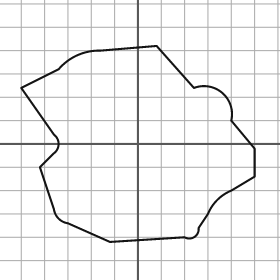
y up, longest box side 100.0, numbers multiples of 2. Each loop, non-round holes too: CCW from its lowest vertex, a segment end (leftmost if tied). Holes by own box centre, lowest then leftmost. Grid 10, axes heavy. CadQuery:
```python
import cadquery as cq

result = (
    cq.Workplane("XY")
    .moveTo(-12.0, -42.0)
    .lineTo(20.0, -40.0)
    .threePointArc((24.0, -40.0), (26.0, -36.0))
    .lineTo(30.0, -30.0)
    .threePointArc((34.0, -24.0), (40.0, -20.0))
    .lineTo(50.0, -14.0)
    .lineTo(50.0, -2.0)
    .lineTo(40.0, 10.0)
    .threePointArc((36.0, 22.0), (24.0, 24.0))
    .lineTo(8.0, 42.0)
    .lineTo(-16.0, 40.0)
    .threePointArc((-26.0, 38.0), (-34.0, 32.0))
    .lineTo(-50.0, 24.0)
    .lineTo(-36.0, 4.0)
    .threePointArc((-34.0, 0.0), (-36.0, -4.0))
    .lineTo(-42.0, -10.0)
    .lineTo(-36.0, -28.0)
    .threePointArc((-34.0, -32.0), (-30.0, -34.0))
    .close()
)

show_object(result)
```